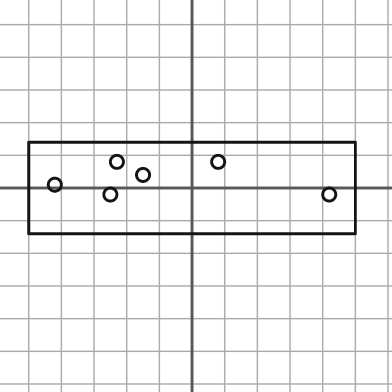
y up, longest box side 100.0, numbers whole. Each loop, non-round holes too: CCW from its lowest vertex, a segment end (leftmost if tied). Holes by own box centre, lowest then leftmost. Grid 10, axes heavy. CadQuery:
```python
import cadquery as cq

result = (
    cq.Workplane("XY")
    .moveTo(-50.0, -14.0)
    .lineTo(50.0, -14.0)
    .lineTo(50.0, 14.0)
    .lineTo(-50.0, 14.0)
    .close()
    .moveTo(-25.0, -2.0)
    .circle(2.0)
    .moveTo(42.0, -2.0)
    .circle(2.0)
    .moveTo(-42.0, 1.0)
    .circle(2.0)
    .moveTo(-15.0, 4.0)
    .circle(2.0)
    .moveTo(-23.0, 8.0)
    .circle(2.0)
    .moveTo(8.0, 8.0)
    .circle(2.0)
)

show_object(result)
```